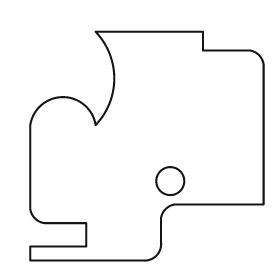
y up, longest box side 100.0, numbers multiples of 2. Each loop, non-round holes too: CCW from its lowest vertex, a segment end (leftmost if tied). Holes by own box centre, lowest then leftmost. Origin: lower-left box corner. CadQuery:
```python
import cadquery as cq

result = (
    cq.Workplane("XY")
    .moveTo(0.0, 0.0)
    .lineTo(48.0, 0.0)
    .threePointArc((54.0, 2.0), (56.0, 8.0))
    .lineTo(56.0, 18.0)
    .threePointArc((58.0, 22.0), (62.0, 24.0))
    .lineTo(100.0, 24.0)
    .lineTo(100.0, 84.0)
    .threePointArc((98.0, 88.0), (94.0, 90.0))
    .lineTo(74.0, 90.0)
    .lineTo(74.0, 98.0)
    .lineTo(28.0, 98.0)
    .threePointArc((36.0, 78.0), (28.0, 58.0))
    .threePointArc((14.0, 70.0), (0.0, 58.0))
    .lineTo(0.0, 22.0)
    .threePointArc((2.0, 18.0), (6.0, 16.0))
    .lineTo(24.0, 16.0)
    .lineTo(24.0, 6.0)
    .lineTo(0.0, 6.0)
    .close()
    .moveTo(60.0, 34.0)
    .circle(6.0)
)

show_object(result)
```